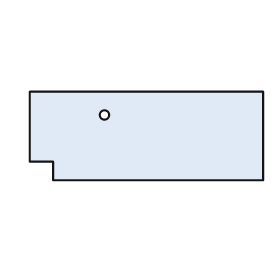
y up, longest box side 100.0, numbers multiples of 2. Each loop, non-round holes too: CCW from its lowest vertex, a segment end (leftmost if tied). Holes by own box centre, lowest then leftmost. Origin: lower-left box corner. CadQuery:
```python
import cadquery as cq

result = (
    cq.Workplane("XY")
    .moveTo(10.0, 0.0)
    .lineTo(100.0, 0.0)
    .lineTo(100.0, 38.0)
    .lineTo(0.0, 38.0)
    .lineTo(0.0, 8.0)
    .lineTo(10.0, 8.0)
    .close()
    .moveTo(32.0, 28.0)
    .circle(2.0)
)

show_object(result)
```